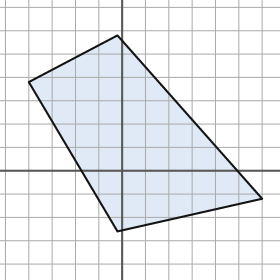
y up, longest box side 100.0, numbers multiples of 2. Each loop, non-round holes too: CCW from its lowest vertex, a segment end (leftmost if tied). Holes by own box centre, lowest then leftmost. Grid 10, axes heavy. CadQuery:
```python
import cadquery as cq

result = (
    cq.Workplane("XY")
    .moveTo(-2.0, -26.0)
    .lineTo(60.0, -12.0)
    .lineTo(-2.0, 58.0)
    .lineTo(-40.0, 38.0)
    .close()
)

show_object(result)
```